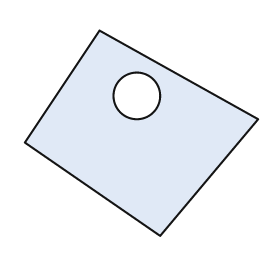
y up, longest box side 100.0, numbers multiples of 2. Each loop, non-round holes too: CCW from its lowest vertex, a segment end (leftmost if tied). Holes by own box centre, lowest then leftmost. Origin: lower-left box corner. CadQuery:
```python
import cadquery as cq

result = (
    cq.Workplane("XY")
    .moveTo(58.0, 0.0)
    .lineTo(100.0, 50.0)
    .lineTo(32.0, 88.0)
    .lineTo(0.0, 40.0)
    .close()
    .moveTo(48.0, 60.0)
    .circle(10.0)
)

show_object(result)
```